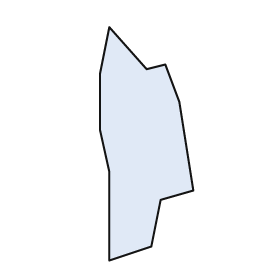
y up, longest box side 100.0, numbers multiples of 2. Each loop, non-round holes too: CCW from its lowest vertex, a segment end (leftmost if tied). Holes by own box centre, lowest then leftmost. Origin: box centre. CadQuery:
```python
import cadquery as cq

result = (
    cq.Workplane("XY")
    .moveTo(-16.0, -50.0)
    .lineTo(2.0, -44.0)
    .lineTo(6.0, -24.0)
    .lineTo(20.0, -20.0)
    .lineTo(14.0, 18.0)
    .lineTo(8.0, 34.0)
    .lineTo(0.0, 32.0)
    .lineTo(-16.0, 50.0)
    .lineTo(-20.0, 30.0)
    .lineTo(-20.0, 6.0)
    .lineTo(-16.0, -12.0)
    .close()
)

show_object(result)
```